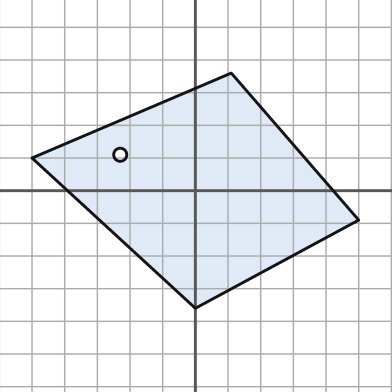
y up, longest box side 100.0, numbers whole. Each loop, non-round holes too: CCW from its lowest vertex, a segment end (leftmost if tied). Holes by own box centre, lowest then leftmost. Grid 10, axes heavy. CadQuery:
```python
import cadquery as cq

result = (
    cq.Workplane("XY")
    .moveTo(0.0, -36.0)
    .lineTo(50.0, -9.0)
    .lineTo(11.0, 36.0)
    .lineTo(-50.0, 10.0)
    .close()
    .moveTo(-23.0, 11.0)
    .circle(2.0)
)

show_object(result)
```